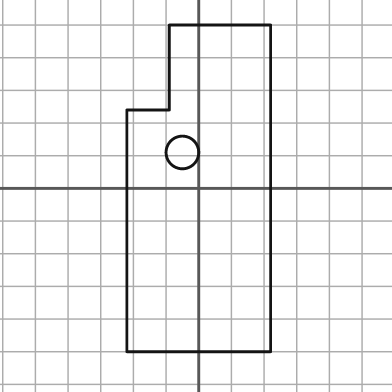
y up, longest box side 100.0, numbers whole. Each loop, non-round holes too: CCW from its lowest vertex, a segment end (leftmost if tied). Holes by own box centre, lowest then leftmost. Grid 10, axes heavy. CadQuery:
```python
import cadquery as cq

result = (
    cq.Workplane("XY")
    .moveTo(-22.0, -50.0)
    .lineTo(22.0, -50.0)
    .lineTo(22.0, 50.0)
    .lineTo(-9.0, 50.0)
    .lineTo(-9.0, 24.0)
    .lineTo(-22.0, 24.0)
    .close()
    .moveTo(-5.0, 11.0)
    .circle(5.0)
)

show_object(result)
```